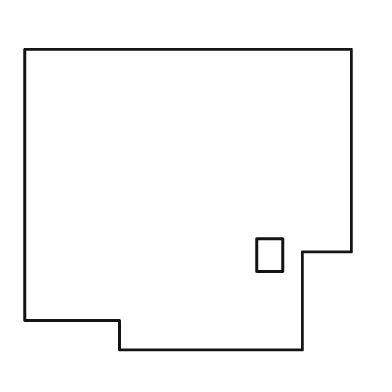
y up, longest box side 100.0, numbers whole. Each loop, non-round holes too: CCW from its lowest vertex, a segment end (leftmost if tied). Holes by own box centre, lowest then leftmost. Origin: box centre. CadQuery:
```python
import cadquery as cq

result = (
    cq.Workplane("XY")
    .moveTo(-21.0, -46.0)
    .lineTo(35.0, -46.0)
    .lineTo(35.0, -16.0)
    .lineTo(50.0, -16.0)
    .lineTo(50.0, 46.0)
    .lineTo(-50.0, 46.0)
    .lineTo(-50.0, -37.0)
    .lineTo(-21.0, -37.0)
    .close()
    .moveTo(21.0, -22.0)
    .lineTo(29.0, -22.0)
    .lineTo(29.0, -12.0)
    .lineTo(21.0, -12.0)
    .close()
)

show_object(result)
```